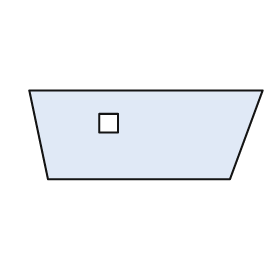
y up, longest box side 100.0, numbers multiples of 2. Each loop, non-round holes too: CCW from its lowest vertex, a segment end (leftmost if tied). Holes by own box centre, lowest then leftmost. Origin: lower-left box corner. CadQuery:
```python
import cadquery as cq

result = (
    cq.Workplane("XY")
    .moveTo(8.0, 0.0)
    .lineTo(86.0, 0.0)
    .lineTo(100.0, 38.0)
    .lineTo(0.0, 38.0)
    .close()
    .moveTo(30.0, 20.0)
    .lineTo(38.0, 20.0)
    .lineTo(38.0, 28.0)
    .lineTo(30.0, 28.0)
    .close()
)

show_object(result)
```